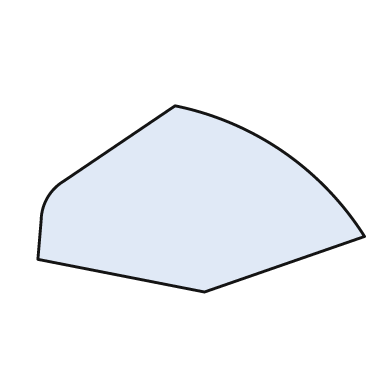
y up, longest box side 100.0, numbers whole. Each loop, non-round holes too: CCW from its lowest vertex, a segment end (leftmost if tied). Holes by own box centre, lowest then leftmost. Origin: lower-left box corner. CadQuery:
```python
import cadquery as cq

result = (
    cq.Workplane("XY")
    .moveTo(51.0, 0.0)
    .lineTo(100.0, 17.0)
    .threePointArc((75.0, 43.0), (42.0, 57.0))
    .lineTo(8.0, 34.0)
    .threePointArc((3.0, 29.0), (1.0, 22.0))
    .lineTo(0.0, 10.0)
    .close()
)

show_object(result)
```